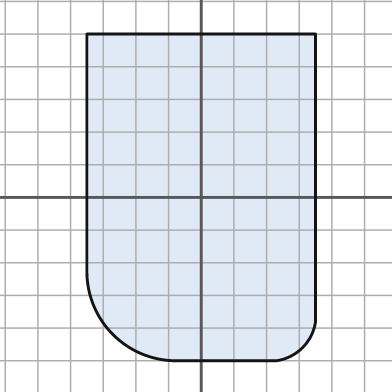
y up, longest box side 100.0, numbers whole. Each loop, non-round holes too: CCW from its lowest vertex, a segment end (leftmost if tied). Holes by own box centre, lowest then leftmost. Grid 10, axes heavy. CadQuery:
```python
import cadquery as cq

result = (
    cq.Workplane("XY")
    .moveTo(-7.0, -50.0)
    .lineTo(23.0, -50.0)
    .threePointArc((31.0, -46.0), (35.0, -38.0))
    .lineTo(35.0, 50.0)
    .lineTo(-35.0, 50.0)
    .lineTo(-35.0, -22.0)
    .threePointArc((-27.0, -42.0), (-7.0, -50.0))
    .close()
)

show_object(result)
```